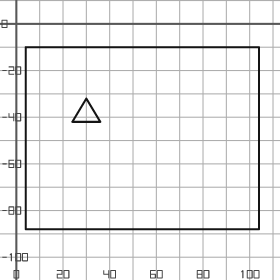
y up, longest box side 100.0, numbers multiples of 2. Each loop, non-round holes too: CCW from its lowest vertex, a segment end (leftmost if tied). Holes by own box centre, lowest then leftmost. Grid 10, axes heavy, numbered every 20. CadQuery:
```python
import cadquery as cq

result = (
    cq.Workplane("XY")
    .moveTo(4.0, -88.0)
    .lineTo(104.0, -88.0)
    .lineTo(104.0, -10.0)
    .lineTo(4.0, -10.0)
    .close()
    .moveTo(24.0, -42.0)
    .lineTo(36.0, -42.0)
    .lineTo(30.0, -32.0)
    .close()
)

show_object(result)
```